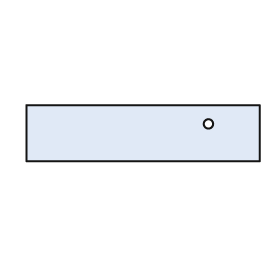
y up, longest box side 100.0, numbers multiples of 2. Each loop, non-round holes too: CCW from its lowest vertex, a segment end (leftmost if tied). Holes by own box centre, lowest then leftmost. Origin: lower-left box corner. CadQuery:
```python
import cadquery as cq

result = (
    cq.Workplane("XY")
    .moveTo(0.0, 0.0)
    .lineTo(100.0, 0.0)
    .lineTo(100.0, 24.0)
    .lineTo(0.0, 24.0)
    .close()
    .moveTo(78.0, 16.0)
    .circle(2.0)
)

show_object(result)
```